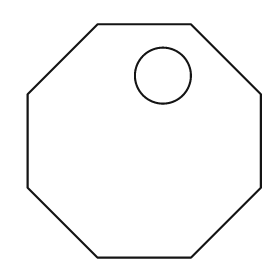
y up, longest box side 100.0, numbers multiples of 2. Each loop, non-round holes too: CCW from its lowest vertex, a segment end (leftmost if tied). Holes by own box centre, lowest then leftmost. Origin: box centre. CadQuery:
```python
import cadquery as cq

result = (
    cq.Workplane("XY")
    .moveTo(-20.0, -50.0)
    .lineTo(20.0, -50.0)
    .lineTo(50.0, -20.0)
    .lineTo(50.0, 20.0)
    .lineTo(20.0, 50.0)
    .lineTo(-20.0, 50.0)
    .lineTo(-50.0, 20.0)
    .lineTo(-50.0, -20.0)
    .close()
    .moveTo(8.0, 28.0)
    .circle(12.0)
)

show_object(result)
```